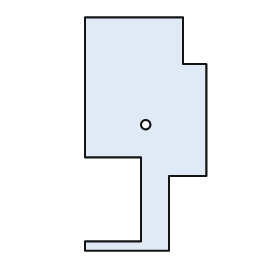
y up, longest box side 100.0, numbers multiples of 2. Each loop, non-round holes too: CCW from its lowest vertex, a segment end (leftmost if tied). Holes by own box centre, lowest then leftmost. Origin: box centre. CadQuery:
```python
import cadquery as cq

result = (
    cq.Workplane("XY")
    .moveTo(-26.0, -50.0)
    .lineTo(10.0, -50.0)
    .lineTo(10.0, -18.0)
    .lineTo(26.0, -18.0)
    .lineTo(26.0, 30.0)
    .lineTo(16.0, 30.0)
    .lineTo(16.0, 50.0)
    .lineTo(-26.0, 50.0)
    .lineTo(-26.0, -10.0)
    .lineTo(-2.0, -10.0)
    .lineTo(-2.0, -46.0)
    .lineTo(-26.0, -46.0)
    .close()
    .moveTo(0.0, 4.0)
    .circle(2.0)
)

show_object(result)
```